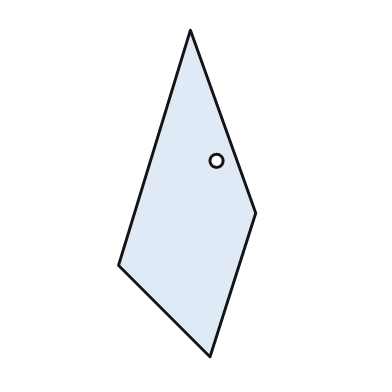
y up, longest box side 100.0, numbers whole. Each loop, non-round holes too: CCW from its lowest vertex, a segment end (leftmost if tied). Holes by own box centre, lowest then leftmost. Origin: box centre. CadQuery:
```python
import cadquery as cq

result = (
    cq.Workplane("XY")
    .moveTo(7.0, -50.0)
    .lineTo(21.0, -6.0)
    .lineTo(1.0, 50.0)
    .lineTo(-21.0, -22.0)
    .close()
    .moveTo(9.0, 10.0)
    .circle(2.0)
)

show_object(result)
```